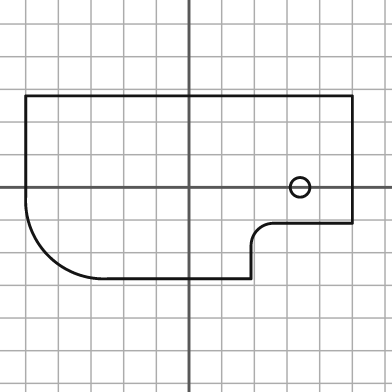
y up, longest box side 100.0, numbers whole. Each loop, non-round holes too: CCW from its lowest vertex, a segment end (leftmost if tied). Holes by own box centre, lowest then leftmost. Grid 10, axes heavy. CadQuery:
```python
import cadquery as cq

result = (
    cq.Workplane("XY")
    .moveTo(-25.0, -28.0)
    .lineTo(19.0, -28.0)
    .lineTo(19.0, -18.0)
    .threePointArc((21.0, -13.0), (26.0, -11.0))
    .lineTo(50.0, -11.0)
    .lineTo(50.0, 28.0)
    .lineTo(-50.0, 28.0)
    .lineTo(-50.0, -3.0)
    .threePointArc((-43.0, -21.0), (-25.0, -28.0))
    .close()
    .moveTo(34.0, 0.0)
    .circle(3.0)
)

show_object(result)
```